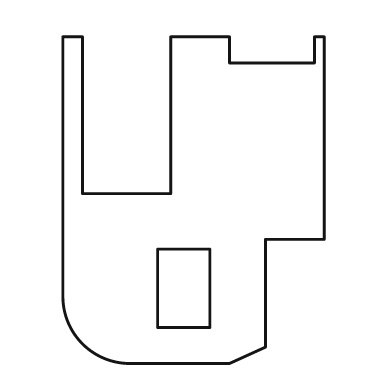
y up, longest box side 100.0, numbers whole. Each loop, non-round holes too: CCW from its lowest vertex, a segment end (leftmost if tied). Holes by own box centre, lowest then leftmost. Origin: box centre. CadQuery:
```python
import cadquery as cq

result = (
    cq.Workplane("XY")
    .moveTo(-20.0, -50.0)
    .lineTo(11.0, -50.0)
    .lineTo(22.0, -45.0)
    .lineTo(22.0, -12.0)
    .lineTo(40.0, -12.0)
    .lineTo(40.0, 50.0)
    .lineTo(37.0, 50.0)
    .lineTo(37.0, 42.0)
    .lineTo(11.0, 42.0)
    .lineTo(11.0, 50.0)
    .lineTo(-7.0, 50.0)
    .lineTo(-7.0, 2.0)
    .lineTo(-34.0, 2.0)
    .lineTo(-34.0, 50.0)
    .lineTo(-40.0, 50.0)
    .lineTo(-40.0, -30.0)
    .threePointArc((-34.0, -44.0), (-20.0, -50.0))
    .close()
    .moveTo(-11.0, -39.0)
    .lineTo(5.0, -39.0)
    .lineTo(5.0, -15.0)
    .lineTo(-11.0, -15.0)
    .close()
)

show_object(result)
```